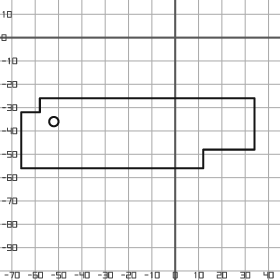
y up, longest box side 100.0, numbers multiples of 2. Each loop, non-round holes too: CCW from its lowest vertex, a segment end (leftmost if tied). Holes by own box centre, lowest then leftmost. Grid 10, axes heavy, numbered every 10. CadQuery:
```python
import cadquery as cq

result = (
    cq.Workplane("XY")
    .moveTo(-66.0, -56.0)
    .lineTo(12.0, -56.0)
    .lineTo(12.0, -48.0)
    .lineTo(34.0, -48.0)
    .lineTo(34.0, -26.0)
    .lineTo(-58.0, -26.0)
    .lineTo(-58.0, -32.0)
    .lineTo(-66.0, -32.0)
    .close()
    .moveTo(-52.0, -36.0)
    .circle(2.0)
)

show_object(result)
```